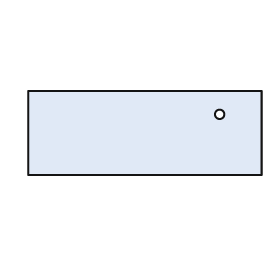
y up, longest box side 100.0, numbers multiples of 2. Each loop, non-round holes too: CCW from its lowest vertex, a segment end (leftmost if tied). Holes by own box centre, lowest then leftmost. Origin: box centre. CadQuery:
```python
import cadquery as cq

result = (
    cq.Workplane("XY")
    .moveTo(-50.0, -18.0)
    .lineTo(50.0, -18.0)
    .lineTo(50.0, 18.0)
    .lineTo(-50.0, 18.0)
    .close()
    .moveTo(32.0, 8.0)
    .circle(2.0)
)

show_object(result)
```